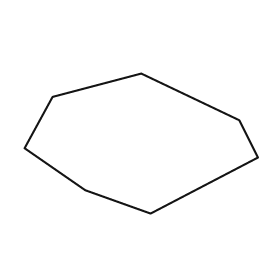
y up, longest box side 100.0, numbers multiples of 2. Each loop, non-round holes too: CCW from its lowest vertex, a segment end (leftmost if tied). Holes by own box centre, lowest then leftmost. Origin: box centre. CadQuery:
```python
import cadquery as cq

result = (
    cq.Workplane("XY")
    .moveTo(4.0, -30.0)
    .lineTo(50.0, -6.0)
    .lineTo(42.0, 10.0)
    .lineTo(0.0, 30.0)
    .lineTo(-38.0, 20.0)
    .lineTo(-50.0, -2.0)
    .lineTo(-24.0, -20.0)
    .close()
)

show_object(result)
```